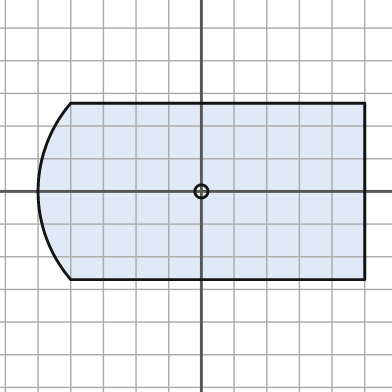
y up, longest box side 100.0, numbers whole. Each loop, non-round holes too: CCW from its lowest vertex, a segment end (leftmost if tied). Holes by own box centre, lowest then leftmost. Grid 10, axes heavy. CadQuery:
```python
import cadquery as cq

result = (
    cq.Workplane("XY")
    .moveTo(-40.0, -27.0)
    .lineTo(50.0, -27.0)
    .lineTo(50.0, 27.0)
    .lineTo(-40.0, 27.0)
    .threePointArc((-50.0, 0.0), (-40.0, -27.0))
    .close()
    .moveTo(0.0, 0.0)
    .circle(2.0)
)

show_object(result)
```